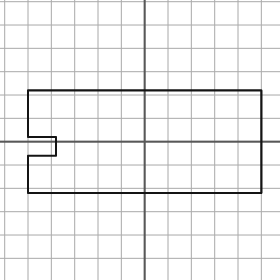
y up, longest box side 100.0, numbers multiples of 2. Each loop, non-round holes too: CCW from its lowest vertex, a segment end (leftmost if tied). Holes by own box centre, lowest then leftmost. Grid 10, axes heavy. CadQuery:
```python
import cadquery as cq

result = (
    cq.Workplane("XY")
    .moveTo(-50.0, -22.0)
    .lineTo(50.0, -22.0)
    .lineTo(50.0, 22.0)
    .lineTo(-50.0, 22.0)
    .lineTo(-50.0, 2.0)
    .lineTo(-38.0, 2.0)
    .lineTo(-38.0, -6.0)
    .lineTo(-50.0, -6.0)
    .close()
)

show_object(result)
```